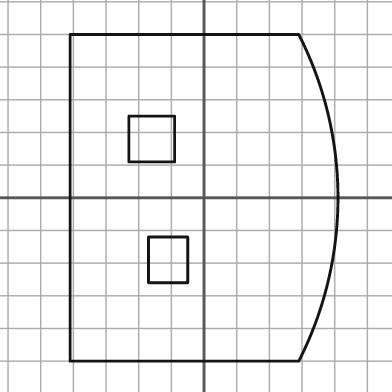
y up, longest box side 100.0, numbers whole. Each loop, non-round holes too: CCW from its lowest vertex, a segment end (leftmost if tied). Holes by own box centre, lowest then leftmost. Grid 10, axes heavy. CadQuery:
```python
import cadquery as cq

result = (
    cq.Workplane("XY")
    .moveTo(-41.0, -50.0)
    .lineTo(29.0, -50.0)
    .threePointArc((41.0, 0.0), (29.0, 50.0))
    .lineTo(-41.0, 50.0)
    .close()
    .moveTo(-17.0, -26.0)
    .lineTo(-5.0, -26.0)
    .lineTo(-5.0, -12.0)
    .lineTo(-17.0, -12.0)
    .close()
    .moveTo(-23.0, 11.0)
    .lineTo(-9.0, 11.0)
    .lineTo(-9.0, 25.0)
    .lineTo(-23.0, 25.0)
    .close()
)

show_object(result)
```